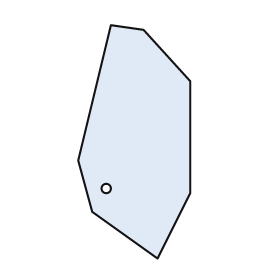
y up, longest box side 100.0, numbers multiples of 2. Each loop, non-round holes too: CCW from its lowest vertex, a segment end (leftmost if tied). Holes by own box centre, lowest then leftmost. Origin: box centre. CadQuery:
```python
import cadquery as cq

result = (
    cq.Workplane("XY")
    .moveTo(10.0, -50.0)
    .lineTo(24.0, -22.0)
    .lineTo(24.0, 26.0)
    .lineTo(4.0, 48.0)
    .lineTo(-10.0, 50.0)
    .lineTo(-24.0, -8.0)
    .lineTo(-18.0, -30.0)
    .close()
    .moveTo(-12.0, -20.0)
    .circle(2.0)
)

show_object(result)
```